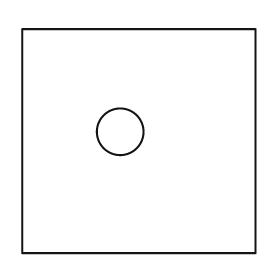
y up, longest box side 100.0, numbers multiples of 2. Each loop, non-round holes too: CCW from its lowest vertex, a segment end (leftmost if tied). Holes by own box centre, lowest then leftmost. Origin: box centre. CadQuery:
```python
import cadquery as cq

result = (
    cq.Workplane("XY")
    .moveTo(-50.0, -48.0)
    .lineTo(50.0, -48.0)
    .lineTo(50.0, 48.0)
    .lineTo(-50.0, 48.0)
    .close()
    .moveTo(-8.0, 4.0)
    .circle(10.0)
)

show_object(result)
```